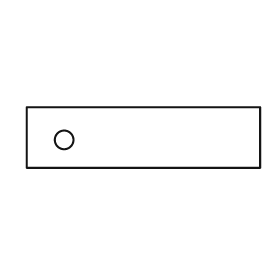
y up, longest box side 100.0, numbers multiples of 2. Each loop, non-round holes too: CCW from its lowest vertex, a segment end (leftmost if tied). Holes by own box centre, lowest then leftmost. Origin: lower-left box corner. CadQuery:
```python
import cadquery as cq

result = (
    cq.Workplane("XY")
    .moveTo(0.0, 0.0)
    .lineTo(100.0, 0.0)
    .lineTo(100.0, 26.0)
    .lineTo(0.0, 26.0)
    .close()
    .moveTo(16.0, 12.0)
    .circle(4.0)
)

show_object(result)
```